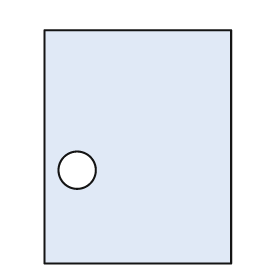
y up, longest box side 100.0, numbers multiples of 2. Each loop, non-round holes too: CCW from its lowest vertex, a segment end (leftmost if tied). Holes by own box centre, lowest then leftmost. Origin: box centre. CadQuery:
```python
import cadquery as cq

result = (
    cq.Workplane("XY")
    .moveTo(-40.0, -50.0)
    .lineTo(40.0, -50.0)
    .lineTo(40.0, 50.0)
    .lineTo(-40.0, 50.0)
    .close()
    .moveTo(-26.0, -10.0)
    .circle(8.0)
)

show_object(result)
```